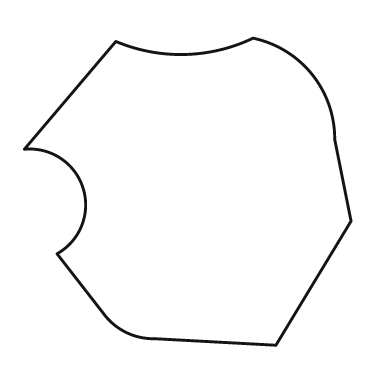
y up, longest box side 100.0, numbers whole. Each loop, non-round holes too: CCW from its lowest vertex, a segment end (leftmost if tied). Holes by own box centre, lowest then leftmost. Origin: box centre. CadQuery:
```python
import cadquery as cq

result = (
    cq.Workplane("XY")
    .moveTo(27.0, -47.0)
    .lineTo(50.0, -9.0)
    .lineTo(45.0, 16.0)
    .threePointArc((38.0, 36.0), (20.0, 47.0))
    .threePointArc((-1.0, 42.0), (-22.0, 46.0))
    .lineTo(-50.0, 13.0)
    .threePointArc((-32.0, 1.0), (-40.0, -19.0))
    .lineTo(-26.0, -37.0)
    .threePointArc((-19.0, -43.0), (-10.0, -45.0))
    .close()
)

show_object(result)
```